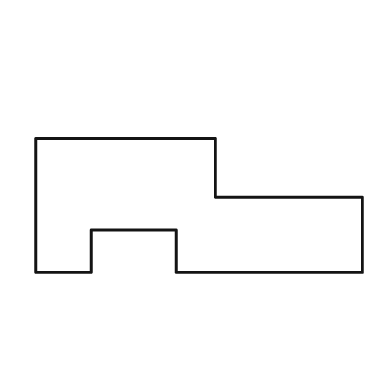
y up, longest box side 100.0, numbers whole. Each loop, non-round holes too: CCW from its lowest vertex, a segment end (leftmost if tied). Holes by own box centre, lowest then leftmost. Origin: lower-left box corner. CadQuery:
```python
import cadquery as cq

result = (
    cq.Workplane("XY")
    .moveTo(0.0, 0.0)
    .lineTo(17.0, 0.0)
    .lineTo(17.0, 13.0)
    .lineTo(43.0, 13.0)
    .lineTo(43.0, 0.0)
    .lineTo(100.0, 0.0)
    .lineTo(100.0, 23.0)
    .lineTo(55.0, 23.0)
    .lineTo(55.0, 41.0)
    .lineTo(0.0, 41.0)
    .close()
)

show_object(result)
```